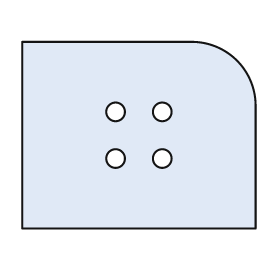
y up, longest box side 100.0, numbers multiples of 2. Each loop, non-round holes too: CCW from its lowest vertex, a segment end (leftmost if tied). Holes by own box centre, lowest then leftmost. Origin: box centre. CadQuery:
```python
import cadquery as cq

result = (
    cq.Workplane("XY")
    .moveTo(-50.0, -40.0)
    .lineTo(50.0, -40.0)
    .lineTo(50.0, 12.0)
    .threePointArc((42.0, 32.0), (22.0, 40.0))
    .lineTo(-50.0, 40.0)
    .close()
    .moveTo(-10.0, -10.0)
    .circle(4.0)
    .moveTo(10.0, -10.0)
    .circle(4.0)
    .moveTo(-10.0, 10.0)
    .circle(4.0)
    .moveTo(10.0, 10.0)
    .circle(4.0)
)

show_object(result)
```